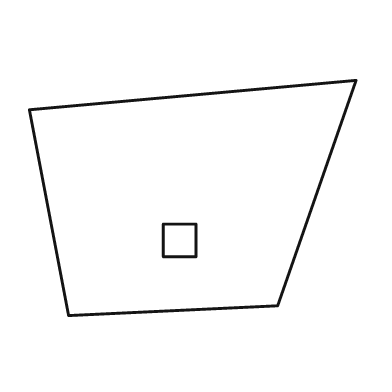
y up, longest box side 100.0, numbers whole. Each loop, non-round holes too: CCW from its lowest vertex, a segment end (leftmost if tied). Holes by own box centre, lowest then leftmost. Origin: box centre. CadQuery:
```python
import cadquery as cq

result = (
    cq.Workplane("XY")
    .moveTo(-38.0, -36.0)
    .lineTo(26.0, -33.0)
    .lineTo(50.0, 36.0)
    .lineTo(-50.0, 27.0)
    .close()
    .moveTo(-9.0, -18.0)
    .lineTo(1.0, -18.0)
    .lineTo(1.0, -8.0)
    .lineTo(-9.0, -8.0)
    .close()
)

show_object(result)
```